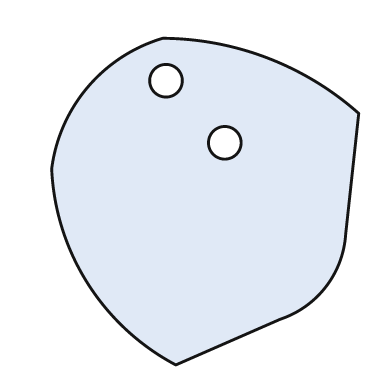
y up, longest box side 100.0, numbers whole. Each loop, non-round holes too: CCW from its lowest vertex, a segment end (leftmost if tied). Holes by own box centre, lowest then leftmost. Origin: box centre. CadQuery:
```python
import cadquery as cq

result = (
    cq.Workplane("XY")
    .moveTo(-9.0, -50.0)
    .lineTo(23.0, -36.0)
    .threePointArc((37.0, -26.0), (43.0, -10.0))
    .lineTo(47.0, 27.0)
    .threePointArc((19.0, 44.0), (-13.0, 50.0))
    .threePointArc((-36.0, 35.0), (-47.0, 10.0))
    .threePointArc((-36.0, -25.0), (-9.0, -50.0))
    .close()
    .moveTo(6.0, 18.0)
    .circle(5.0)
    .moveTo(-12.0, 37.0)
    .circle(5.0)
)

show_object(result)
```